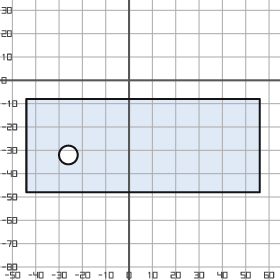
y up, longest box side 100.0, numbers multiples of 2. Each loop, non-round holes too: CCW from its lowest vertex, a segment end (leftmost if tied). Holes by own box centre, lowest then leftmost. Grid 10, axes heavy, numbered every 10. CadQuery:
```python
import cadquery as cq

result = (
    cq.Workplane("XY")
    .moveTo(-44.0, -48.0)
    .lineTo(56.0, -48.0)
    .lineTo(56.0, -8.0)
    .lineTo(-44.0, -8.0)
    .close()
    .moveTo(-26.0, -32.0)
    .circle(4.0)
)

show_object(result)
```